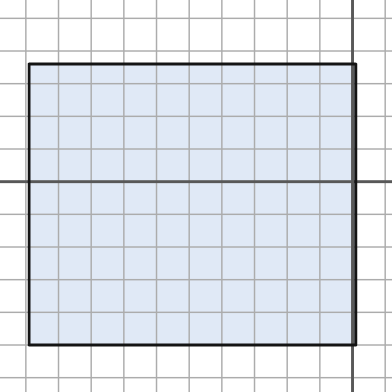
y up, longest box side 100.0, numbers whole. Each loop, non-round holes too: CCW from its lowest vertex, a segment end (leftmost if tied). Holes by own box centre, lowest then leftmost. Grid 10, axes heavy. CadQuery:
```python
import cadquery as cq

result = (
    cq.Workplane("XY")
    .moveTo(-99.0, -50.0)
    .lineTo(1.0, -50.0)
    .lineTo(1.0, 36.0)
    .lineTo(-99.0, 36.0)
    .close()
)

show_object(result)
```